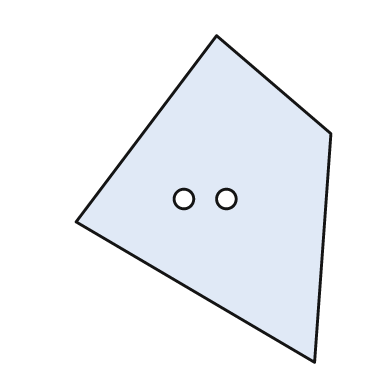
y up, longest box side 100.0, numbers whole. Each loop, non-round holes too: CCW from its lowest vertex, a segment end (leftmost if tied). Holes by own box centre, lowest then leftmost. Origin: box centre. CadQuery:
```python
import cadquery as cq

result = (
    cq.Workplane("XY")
    .moveTo(34.0, -50.0)
    .lineTo(39.0, 20.0)
    .lineTo(4.0, 50.0)
    .lineTo(-39.0, -7.0)
    .close()
    .moveTo(-6.0, 0.0)
    .circle(3.0)
    .moveTo(7.0, 0.0)
    .circle(3.0)
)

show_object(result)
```